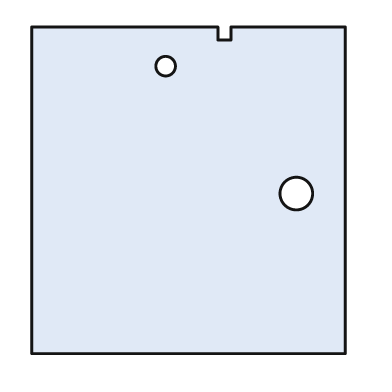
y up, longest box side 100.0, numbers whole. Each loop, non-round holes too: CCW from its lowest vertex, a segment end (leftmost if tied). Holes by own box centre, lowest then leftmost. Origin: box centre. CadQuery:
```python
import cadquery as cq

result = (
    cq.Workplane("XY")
    .moveTo(-48.0, -50.0)
    .lineTo(48.0, -50.0)
    .lineTo(48.0, 50.0)
    .lineTo(13.0, 50.0)
    .lineTo(13.0, 46.0)
    .lineTo(9.0, 46.0)
    .lineTo(9.0, 50.0)
    .lineTo(-48.0, 50.0)
    .close()
    .moveTo(33.0, -1.0)
    .circle(5.0)
    .moveTo(-7.0, 38.0)
    .circle(3.0)
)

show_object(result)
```